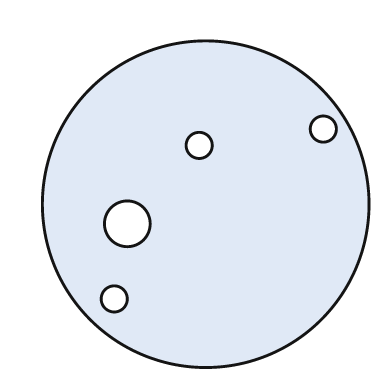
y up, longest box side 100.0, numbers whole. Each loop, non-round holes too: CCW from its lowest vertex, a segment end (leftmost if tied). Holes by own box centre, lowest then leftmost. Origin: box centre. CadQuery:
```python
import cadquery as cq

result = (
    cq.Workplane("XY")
    .moveTo(0.0, 0.0)
    .circle(50.0)
    .moveTo(-28.0, -29.0)
    .circle(4.0)
    .moveTo(-24.0, -6.0)
    .circle(7.0)
    .moveTo(-2.0, 18.0)
    .circle(4.0)
    .moveTo(36.0, 23.0)
    .circle(4.0)
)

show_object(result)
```